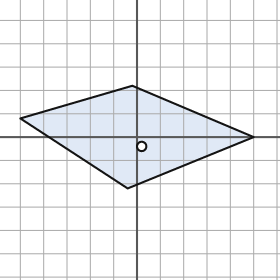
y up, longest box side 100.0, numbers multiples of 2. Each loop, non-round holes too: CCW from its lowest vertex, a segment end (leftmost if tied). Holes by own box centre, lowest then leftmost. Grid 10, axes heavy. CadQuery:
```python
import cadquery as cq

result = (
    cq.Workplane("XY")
    .moveTo(-4.0, -22.0)
    .lineTo(50.0, 0.0)
    .lineTo(-2.0, 22.0)
    .lineTo(-50.0, 8.0)
    .close()
    .moveTo(2.0, -4.0)
    .circle(2.0)
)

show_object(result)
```